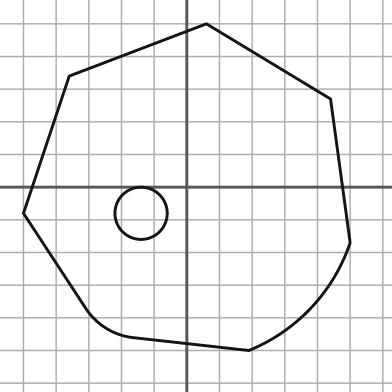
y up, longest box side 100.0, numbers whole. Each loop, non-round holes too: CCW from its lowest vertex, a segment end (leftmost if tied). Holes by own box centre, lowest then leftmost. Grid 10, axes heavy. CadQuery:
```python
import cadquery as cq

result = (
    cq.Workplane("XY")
    .moveTo(19.0, -50.0)
    .threePointArc((38.0, -37.0), (50.0, -17.0))
    .lineTo(44.0, 27.0)
    .lineTo(6.0, 50.0)
    .lineTo(-36.0, 34.0)
    .lineTo(-50.0, -8.0)
    .lineTo(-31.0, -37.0)
    .threePointArc((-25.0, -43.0), (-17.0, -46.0))
    .close()
    .moveTo(-14.0, -8.0)
    .circle(8.0)
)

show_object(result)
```